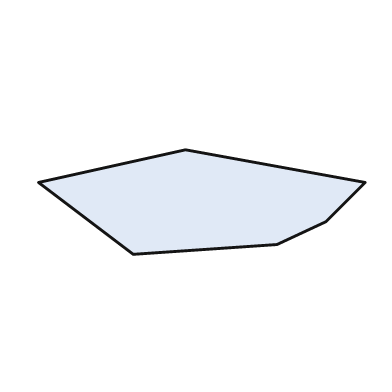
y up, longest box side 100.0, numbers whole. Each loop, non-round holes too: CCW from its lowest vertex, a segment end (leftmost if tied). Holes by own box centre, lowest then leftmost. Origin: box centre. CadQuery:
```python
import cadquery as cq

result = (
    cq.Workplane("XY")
    .moveTo(-21.0, -16.0)
    .lineTo(23.0, -13.0)
    .lineTo(38.0, -6.0)
    .lineTo(50.0, 6.0)
    .lineTo(-5.0, 16.0)
    .lineTo(-50.0, 6.0)
    .close()
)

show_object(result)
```